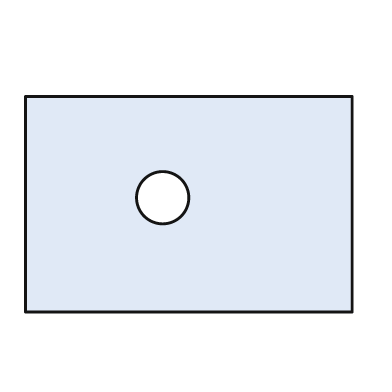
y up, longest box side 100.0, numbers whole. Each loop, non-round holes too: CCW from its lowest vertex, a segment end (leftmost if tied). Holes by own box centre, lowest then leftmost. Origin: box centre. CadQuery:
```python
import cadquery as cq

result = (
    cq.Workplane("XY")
    .moveTo(-50.0, -33.0)
    .lineTo(50.0, -33.0)
    .lineTo(50.0, 33.0)
    .lineTo(-50.0, 33.0)
    .close()
    .moveTo(-8.0, 2.0)
    .circle(8.0)
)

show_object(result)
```